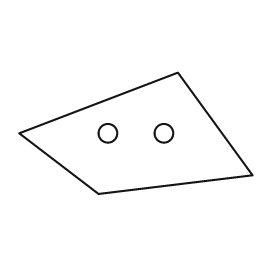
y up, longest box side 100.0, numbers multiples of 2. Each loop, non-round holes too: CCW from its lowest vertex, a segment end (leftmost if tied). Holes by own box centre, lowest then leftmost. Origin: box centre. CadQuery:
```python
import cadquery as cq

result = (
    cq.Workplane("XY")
    .moveTo(-16.0, -26.0)
    .lineTo(50.0, -18.0)
    .lineTo(18.0, 26.0)
    .lineTo(-50.0, 0.0)
    .close()
    .moveTo(-12.0, 0.0)
    .circle(4.0)
    .moveTo(12.0, 0.0)
    .circle(4.0)
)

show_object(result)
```